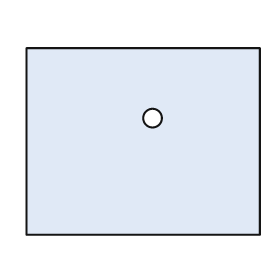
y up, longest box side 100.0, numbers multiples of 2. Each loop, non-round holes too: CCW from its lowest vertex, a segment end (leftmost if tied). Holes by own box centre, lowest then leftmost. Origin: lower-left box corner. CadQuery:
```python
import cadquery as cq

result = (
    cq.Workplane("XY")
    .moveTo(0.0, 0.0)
    .lineTo(100.0, 0.0)
    .lineTo(100.0, 80.0)
    .lineTo(0.0, 80.0)
    .close()
    .moveTo(54.0, 50.0)
    .circle(4.0)
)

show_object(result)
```